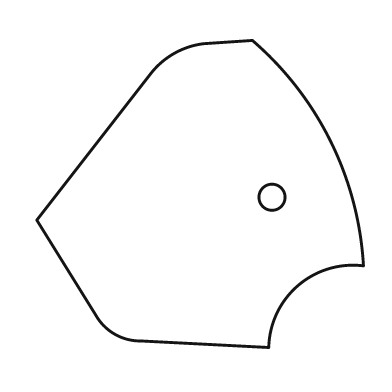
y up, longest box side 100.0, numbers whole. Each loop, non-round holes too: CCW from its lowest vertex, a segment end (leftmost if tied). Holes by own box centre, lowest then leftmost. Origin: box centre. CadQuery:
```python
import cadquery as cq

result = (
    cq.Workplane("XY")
    .moveTo(21.0, -47.0)
    .threePointArc((30.0, -28.0), (50.0, -22.0))
    .threePointArc((40.0, 16.0), (16.0, 47.0))
    .lineTo(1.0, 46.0)
    .threePointArc((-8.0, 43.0), (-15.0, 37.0))
    .lineTo(-50.0, -8.0)
    .lineTo(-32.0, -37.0)
    .threePointArc((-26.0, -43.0), (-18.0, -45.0))
    .close()
    .moveTo(22.0, -1.0)
    .circle(4.0)
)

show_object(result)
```